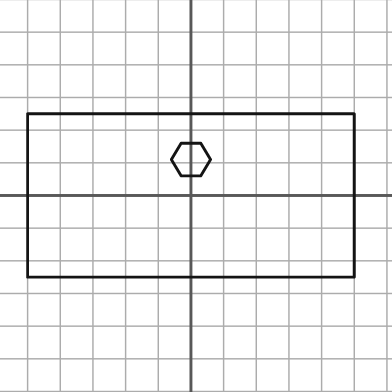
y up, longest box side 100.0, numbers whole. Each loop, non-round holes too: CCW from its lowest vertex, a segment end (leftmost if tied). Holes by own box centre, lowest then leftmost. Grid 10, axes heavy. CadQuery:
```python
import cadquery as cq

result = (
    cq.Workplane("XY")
    .moveTo(-50.0, -25.0)
    .lineTo(50.0, -25.0)
    .lineTo(50.0, 25.0)
    .lineTo(-50.0, 25.0)
    .close()
    .moveTo(-3.0, 6.0)
    .lineTo(3.0, 6.0)
    .lineTo(6.0, 11.0)
    .lineTo(3.0, 16.0)
    .lineTo(-3.0, 16.0)
    .lineTo(-6.0, 11.0)
    .close()
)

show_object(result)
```